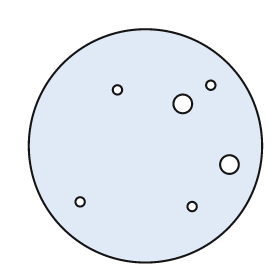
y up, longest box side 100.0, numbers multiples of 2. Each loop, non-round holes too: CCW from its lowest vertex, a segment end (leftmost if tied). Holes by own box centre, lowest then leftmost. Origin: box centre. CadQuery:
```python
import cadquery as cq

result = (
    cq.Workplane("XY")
    .moveTo(0.0, 0.0)
    .circle(50.0)
    .moveTo(20.0, -26.0)
    .circle(2.0)
    .moveTo(-28.0, -24.0)
    .circle(2.0)
    .moveTo(36.0, -8.0)
    .circle(4.0)
    .moveTo(16.0, 18.0)
    .circle(4.0)
    .moveTo(-12.0, 24.0)
    .circle(2.0)
    .moveTo(28.0, 26.0)
    .circle(2.0)
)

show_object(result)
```